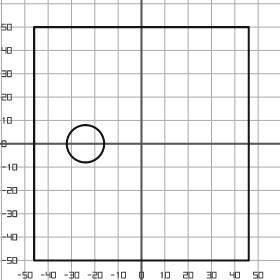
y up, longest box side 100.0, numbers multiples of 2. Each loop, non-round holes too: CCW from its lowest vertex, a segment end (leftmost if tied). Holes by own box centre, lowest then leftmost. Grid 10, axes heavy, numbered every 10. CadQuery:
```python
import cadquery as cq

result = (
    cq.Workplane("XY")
    .moveTo(-46.0, -50.0)
    .lineTo(46.0, -50.0)
    .lineTo(46.0, 50.0)
    .lineTo(-46.0, 50.0)
    .close()
    .moveTo(-24.0, 0.0)
    .circle(8.0)
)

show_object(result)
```